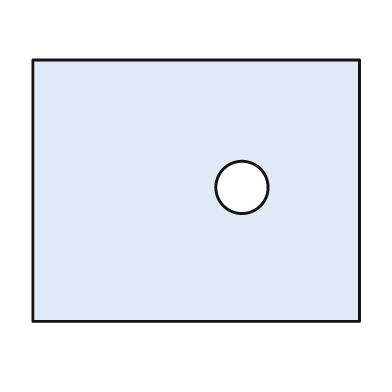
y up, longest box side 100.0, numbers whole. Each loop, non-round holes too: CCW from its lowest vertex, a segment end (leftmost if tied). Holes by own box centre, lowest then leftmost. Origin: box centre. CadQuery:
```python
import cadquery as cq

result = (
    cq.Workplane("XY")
    .moveTo(-50.0, -40.0)
    .lineTo(50.0, -40.0)
    .lineTo(50.0, 40.0)
    .lineTo(-50.0, 40.0)
    .close()
    .moveTo(14.0, 1.0)
    .circle(8.0)
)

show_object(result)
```